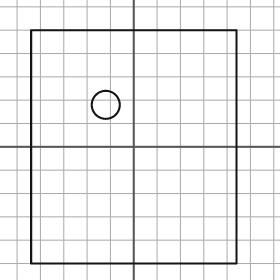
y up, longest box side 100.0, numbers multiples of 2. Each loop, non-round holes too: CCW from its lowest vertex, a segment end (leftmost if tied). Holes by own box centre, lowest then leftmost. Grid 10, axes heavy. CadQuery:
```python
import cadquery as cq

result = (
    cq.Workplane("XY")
    .moveTo(-44.0, -50.0)
    .lineTo(44.0, -50.0)
    .lineTo(44.0, 50.0)
    .lineTo(-44.0, 50.0)
    .close()
    .moveTo(-12.0, 18.0)
    .circle(6.0)
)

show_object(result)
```